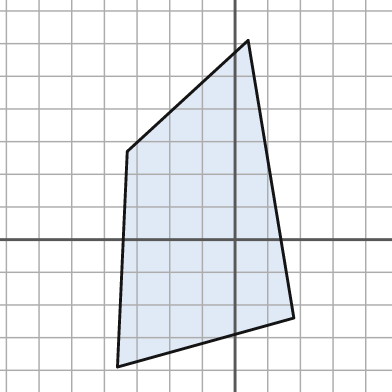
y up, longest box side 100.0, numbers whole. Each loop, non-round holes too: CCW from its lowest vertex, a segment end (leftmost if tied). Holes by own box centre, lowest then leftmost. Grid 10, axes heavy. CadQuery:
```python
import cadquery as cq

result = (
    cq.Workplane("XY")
    .moveTo(-36.0, -39.0)
    .lineTo(18.0, -24.0)
    .lineTo(4.0, 61.0)
    .lineTo(-33.0, 27.0)
    .close()
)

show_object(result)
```